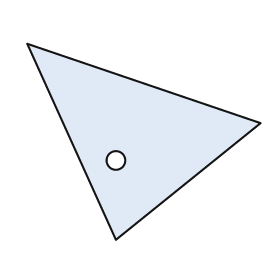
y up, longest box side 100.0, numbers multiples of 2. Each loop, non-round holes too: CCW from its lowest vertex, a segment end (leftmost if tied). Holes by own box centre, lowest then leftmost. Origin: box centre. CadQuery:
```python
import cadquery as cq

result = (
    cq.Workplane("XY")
    .moveTo(-12.0, -42.0)
    .lineTo(50.0, 8.0)
    .lineTo(-50.0, 42.0)
    .close()
    .moveTo(-12.0, -8.0)
    .circle(4.0)
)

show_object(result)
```